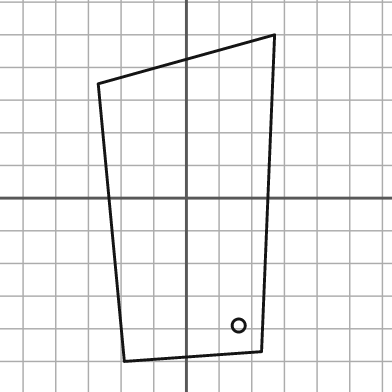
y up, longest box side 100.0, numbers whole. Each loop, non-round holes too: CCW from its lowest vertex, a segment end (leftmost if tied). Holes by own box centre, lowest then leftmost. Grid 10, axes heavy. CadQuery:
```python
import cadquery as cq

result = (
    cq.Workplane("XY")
    .moveTo(-19.0, -50.0)
    .lineTo(23.0, -47.0)
    .lineTo(27.0, 50.0)
    .lineTo(-27.0, 35.0)
    .close()
    .moveTo(16.0, -39.0)
    .circle(2.0)
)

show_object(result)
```